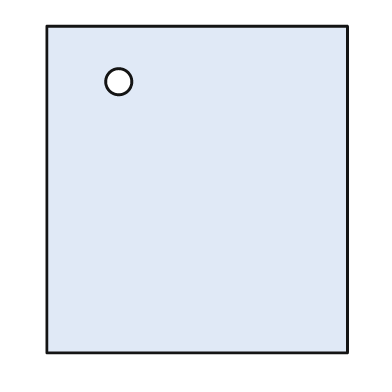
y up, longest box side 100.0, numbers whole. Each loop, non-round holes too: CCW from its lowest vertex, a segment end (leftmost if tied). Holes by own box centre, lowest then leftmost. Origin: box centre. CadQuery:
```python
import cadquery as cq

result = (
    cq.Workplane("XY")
    .moveTo(-46.0, -50.0)
    .lineTo(46.0, -50.0)
    .lineTo(46.0, 50.0)
    .lineTo(-46.0, 50.0)
    .close()
    .moveTo(-24.0, 33.0)
    .circle(4.0)
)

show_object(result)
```